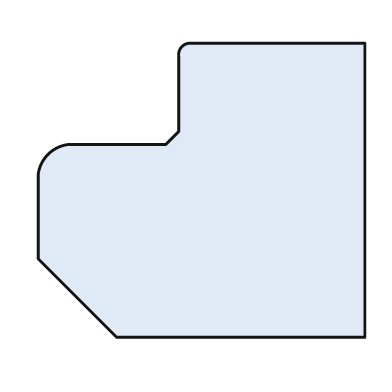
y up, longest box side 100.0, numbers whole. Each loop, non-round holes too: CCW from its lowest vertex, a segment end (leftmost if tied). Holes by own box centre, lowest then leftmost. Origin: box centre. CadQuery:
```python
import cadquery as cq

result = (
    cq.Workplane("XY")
    .moveTo(-26.0, -45.0)
    .lineTo(50.0, -45.0)
    .lineTo(50.0, 45.0)
    .lineTo(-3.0, 45.0)
    .threePointArc((-6.0, 44.0), (-7.0, 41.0))
    .lineTo(-7.0, 18.0)
    .lineTo(-11.0, 14.0)
    .lineTo(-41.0, 14.0)
    .threePointArc((-47.0, 11.0), (-50.0, 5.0))
    .lineTo(-50.0, -21.0)
    .close()
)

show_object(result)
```